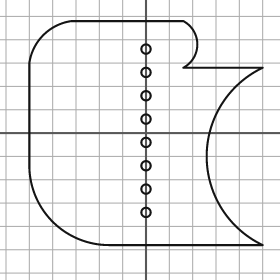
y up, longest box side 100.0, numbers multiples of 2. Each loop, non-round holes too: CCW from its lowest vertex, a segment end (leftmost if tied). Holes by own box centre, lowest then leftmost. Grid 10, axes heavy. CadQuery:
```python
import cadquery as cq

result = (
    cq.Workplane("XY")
    .moveTo(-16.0, -48.0)
    .lineTo(50.0, -48.0)
    .threePointArc((26.0, -10.0), (50.0, 28.0))
    .lineTo(16.0, 28.0)
    .threePointArc((22.0, 38.0), (16.0, 48.0))
    .lineTo(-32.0, 48.0)
    .threePointArc((-44.0, 42.0), (-50.0, 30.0))
    .lineTo(-50.0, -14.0)
    .threePointArc((-40.0, -38.0), (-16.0, -48.0))
    .close()
    .moveTo(0.0, -34.0)
    .circle(2.0)
    .moveTo(0.0, -24.0)
    .circle(2.0)
    .moveTo(0.0, -14.0)
    .circle(2.0)
    .moveTo(0.0, -4.0)
    .circle(2.0)
    .moveTo(0.0, 6.0)
    .circle(2.0)
    .moveTo(0.0, 16.0)
    .circle(2.0)
    .moveTo(0.0, 26.0)
    .circle(2.0)
    .moveTo(0.0, 36.0)
    .circle(2.0)
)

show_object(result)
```